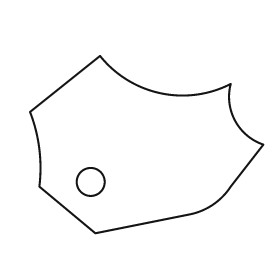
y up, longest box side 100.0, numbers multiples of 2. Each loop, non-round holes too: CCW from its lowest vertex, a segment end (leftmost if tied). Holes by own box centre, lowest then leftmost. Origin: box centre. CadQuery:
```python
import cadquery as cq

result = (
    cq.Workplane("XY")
    .moveTo(-22.0, -38.0)
    .lineTo(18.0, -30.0)
    .threePointArc((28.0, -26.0), (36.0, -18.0))
    .lineTo(50.0, 0.0)
    .threePointArc((38.0, 10.0), (36.0, 26.0))
    .threePointArc((6.0, 22.0), (-20.0, 38.0))
    .lineTo(-50.0, 14.0)
    .threePointArc((-46.0, -2.0), (-46.0, -18.0))
    .close()
    .moveTo(-24.0, -16.0)
    .circle(6.0)
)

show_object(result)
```